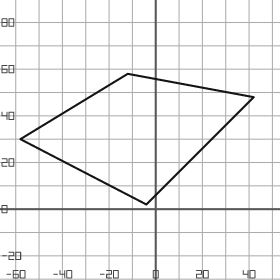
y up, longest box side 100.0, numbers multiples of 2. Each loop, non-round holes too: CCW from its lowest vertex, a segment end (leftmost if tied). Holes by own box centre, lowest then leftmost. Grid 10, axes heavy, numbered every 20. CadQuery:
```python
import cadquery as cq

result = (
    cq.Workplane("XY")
    .moveTo(-4.0, 2.0)
    .lineTo(42.0, 48.0)
    .lineTo(-12.0, 58.0)
    .lineTo(-58.0, 30.0)
    .close()
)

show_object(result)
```